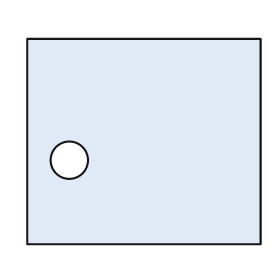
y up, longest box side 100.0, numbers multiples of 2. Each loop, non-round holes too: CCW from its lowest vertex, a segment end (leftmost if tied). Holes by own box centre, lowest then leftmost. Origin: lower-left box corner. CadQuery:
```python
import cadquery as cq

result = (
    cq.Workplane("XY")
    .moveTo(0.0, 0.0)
    .lineTo(100.0, 0.0)
    .lineTo(100.0, 88.0)
    .lineTo(0.0, 88.0)
    .close()
    .moveTo(18.0, 36.0)
    .circle(8.0)
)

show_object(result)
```